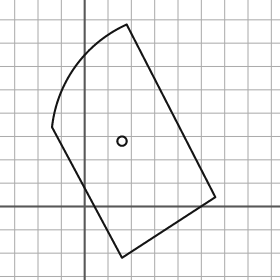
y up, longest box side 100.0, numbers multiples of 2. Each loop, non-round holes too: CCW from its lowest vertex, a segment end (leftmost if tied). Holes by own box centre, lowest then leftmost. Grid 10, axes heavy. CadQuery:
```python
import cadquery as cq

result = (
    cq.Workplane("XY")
    .moveTo(16.0, -22.0)
    .lineTo(56.0, 4.0)
    .lineTo(18.0, 78.0)
    .threePointArc((-4.0, 60.0), (-14.0, 34.0))
    .close()
    .moveTo(16.0, 28.0)
    .circle(2.0)
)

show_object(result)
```